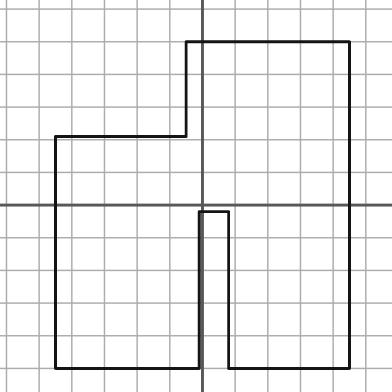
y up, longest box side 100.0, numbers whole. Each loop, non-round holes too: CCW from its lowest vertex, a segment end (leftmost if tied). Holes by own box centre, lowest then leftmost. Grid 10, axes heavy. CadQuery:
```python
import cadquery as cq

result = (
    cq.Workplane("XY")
    .moveTo(-45.0, -50.0)
    .lineTo(-1.0, -50.0)
    .lineTo(-1.0, -2.0)
    .lineTo(8.0, -2.0)
    .lineTo(8.0, -50.0)
    .lineTo(45.0, -50.0)
    .lineTo(45.0, 50.0)
    .lineTo(-5.0, 50.0)
    .lineTo(-5.0, 21.0)
    .lineTo(-45.0, 21.0)
    .close()
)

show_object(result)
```